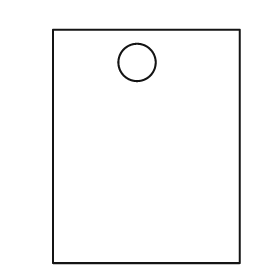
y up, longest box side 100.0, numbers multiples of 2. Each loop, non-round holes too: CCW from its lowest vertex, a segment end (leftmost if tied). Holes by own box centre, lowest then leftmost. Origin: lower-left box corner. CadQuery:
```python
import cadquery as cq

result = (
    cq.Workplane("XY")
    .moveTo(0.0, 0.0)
    .lineTo(80.0, 0.0)
    .lineTo(80.0, 100.0)
    .lineTo(0.0, 100.0)
    .close()
    .moveTo(36.0, 86.0)
    .circle(8.0)
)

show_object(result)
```